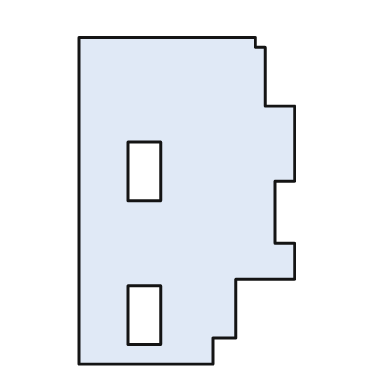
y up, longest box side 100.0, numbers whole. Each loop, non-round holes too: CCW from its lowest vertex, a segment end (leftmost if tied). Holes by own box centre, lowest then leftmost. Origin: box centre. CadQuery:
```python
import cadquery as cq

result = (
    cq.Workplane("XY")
    .moveTo(-33.0, -50.0)
    .lineTo(8.0, -50.0)
    .lineTo(8.0, -42.0)
    .lineTo(15.0, -42.0)
    .lineTo(15.0, -24.0)
    .lineTo(33.0, -24.0)
    .lineTo(33.0, -13.0)
    .lineTo(27.0, -13.0)
    .lineTo(27.0, 6.0)
    .lineTo(33.0, 6.0)
    .lineTo(33.0, 29.0)
    .lineTo(24.0, 29.0)
    .lineTo(24.0, 47.0)
    .lineTo(21.0, 47.0)
    .lineTo(21.0, 50.0)
    .lineTo(-33.0, 50.0)
    .close()
    .moveTo(-18.0, -44.0)
    .lineTo(-8.0, -44.0)
    .lineTo(-8.0, -26.0)
    .lineTo(-18.0, -26.0)
    .close()
    .moveTo(-18.0, 0.0)
    .lineTo(-8.0, 0.0)
    .lineTo(-8.0, 18.0)
    .lineTo(-18.0, 18.0)
    .close()
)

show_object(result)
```